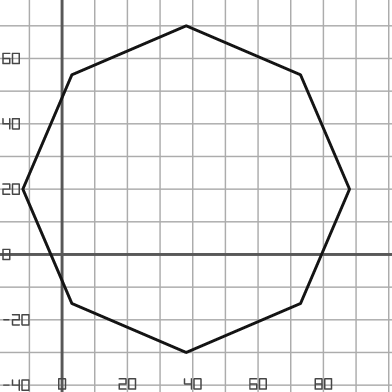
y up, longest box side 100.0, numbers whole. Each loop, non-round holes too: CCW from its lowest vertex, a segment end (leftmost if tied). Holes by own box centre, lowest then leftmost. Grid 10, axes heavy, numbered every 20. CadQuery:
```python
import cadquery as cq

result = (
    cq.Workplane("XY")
    .moveTo(38.0, -30.0)
    .lineTo(73.0, -15.0)
    .lineTo(88.0, 20.0)
    .lineTo(73.0, 55.0)
    .lineTo(38.0, 70.0)
    .lineTo(3.0, 55.0)
    .lineTo(-12.0, 20.0)
    .lineTo(3.0, -15.0)
    .close()
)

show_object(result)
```